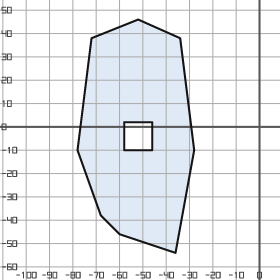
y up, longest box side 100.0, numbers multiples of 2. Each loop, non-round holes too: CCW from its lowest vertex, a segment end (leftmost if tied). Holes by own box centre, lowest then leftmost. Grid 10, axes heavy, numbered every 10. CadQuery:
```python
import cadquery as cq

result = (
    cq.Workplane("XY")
    .moveTo(-36.0, -54.0)
    .lineTo(-28.0, -10.0)
    .lineTo(-34.0, 38.0)
    .lineTo(-52.0, 46.0)
    .lineTo(-72.0, 38.0)
    .lineTo(-78.0, -10.0)
    .lineTo(-68.0, -38.0)
    .lineTo(-60.0, -46.0)
    .close()
    .moveTo(-58.0, -10.0)
    .lineTo(-46.0, -10.0)
    .lineTo(-46.0, 2.0)
    .lineTo(-58.0, 2.0)
    .close()
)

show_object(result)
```